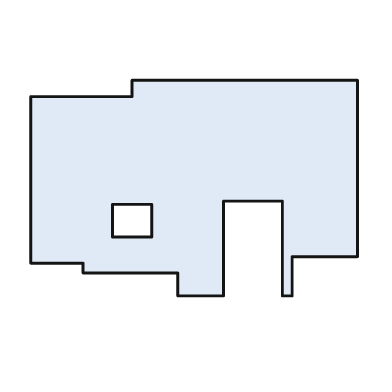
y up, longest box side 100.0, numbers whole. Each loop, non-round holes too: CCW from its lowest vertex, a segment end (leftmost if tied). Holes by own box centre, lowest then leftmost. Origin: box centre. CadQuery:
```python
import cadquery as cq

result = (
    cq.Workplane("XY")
    .moveTo(-5.0, -33.0)
    .lineTo(9.0, -33.0)
    .lineTo(9.0, -4.0)
    .lineTo(27.0, -4.0)
    .lineTo(27.0, -33.0)
    .lineTo(30.0, -33.0)
    .lineTo(30.0, -21.0)
    .lineTo(50.0, -21.0)
    .lineTo(50.0, 33.0)
    .lineTo(-19.0, 33.0)
    .lineTo(-19.0, 28.0)
    .lineTo(-50.0, 28.0)
    .lineTo(-50.0, -23.0)
    .lineTo(-34.0, -23.0)
    .lineTo(-34.0, -26.0)
    .lineTo(-5.0, -26.0)
    .close()
    .moveTo(-25.0, -15.0)
    .lineTo(-13.0, -15.0)
    .lineTo(-13.0, -5.0)
    .lineTo(-25.0, -5.0)
    .close()
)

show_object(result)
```